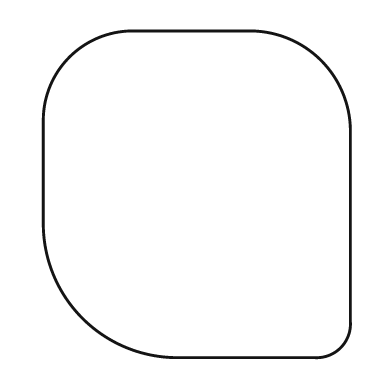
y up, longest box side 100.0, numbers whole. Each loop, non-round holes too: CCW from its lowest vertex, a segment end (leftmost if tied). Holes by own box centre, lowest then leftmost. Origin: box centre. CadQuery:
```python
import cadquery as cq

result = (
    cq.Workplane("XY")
    .moveTo(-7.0, -50.0)
    .lineTo(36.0, -50.0)
    .threePointArc((44.0, -47.0), (47.0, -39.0))
    .lineTo(47.0, 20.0)
    .threePointArc((38.0, 41.0), (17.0, 50.0))
    .lineTo(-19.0, 50.0)
    .threePointArc((-39.0, 42.0), (-47.0, 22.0))
    .lineTo(-47.0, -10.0)
    .threePointArc((-35.0, -38.0), (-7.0, -50.0))
    .close()
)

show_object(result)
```